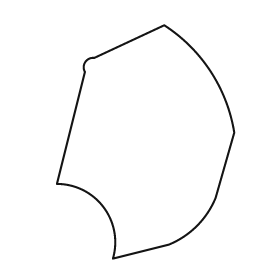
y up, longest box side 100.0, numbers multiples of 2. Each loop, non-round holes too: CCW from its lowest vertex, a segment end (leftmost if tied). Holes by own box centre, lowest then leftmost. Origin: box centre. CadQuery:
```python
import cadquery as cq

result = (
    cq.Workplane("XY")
    .moveTo(-14.0, -50.0)
    .lineTo(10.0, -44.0)
    .threePointArc((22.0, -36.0), (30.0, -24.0))
    .lineTo(38.0, 4.0)
    .threePointArc((28.0, 30.0), (8.0, 50.0))
    .lineTo(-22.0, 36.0)
    .threePointArc((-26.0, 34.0), (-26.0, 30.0))
    .lineTo(-38.0, -18.0)
    .threePointArc((-18.0, -28.0), (-14.0, -50.0))
    .close()
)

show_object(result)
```